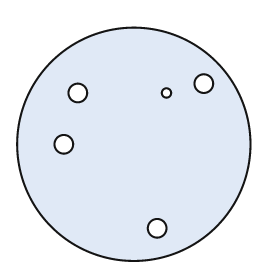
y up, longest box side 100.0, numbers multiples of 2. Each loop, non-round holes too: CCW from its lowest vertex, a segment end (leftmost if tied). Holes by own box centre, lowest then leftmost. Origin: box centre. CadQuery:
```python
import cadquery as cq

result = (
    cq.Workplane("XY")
    .moveTo(0.0, 0.0)
    .circle(50.0)
    .moveTo(10.0, -36.0)
    .circle(4.0)
    .moveTo(-30.0, 0.0)
    .circle(4.0)
    .moveTo(-24.0, 22.0)
    .circle(4.0)
    .moveTo(14.0, 22.0)
    .circle(2.0)
    .moveTo(30.0, 26.0)
    .circle(4.0)
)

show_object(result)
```